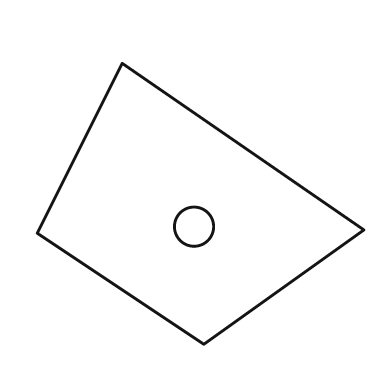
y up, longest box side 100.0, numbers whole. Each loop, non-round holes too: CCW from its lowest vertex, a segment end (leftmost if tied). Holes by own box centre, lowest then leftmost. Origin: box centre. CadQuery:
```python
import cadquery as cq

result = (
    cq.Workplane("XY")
    .moveTo(1.0, -43.0)
    .lineTo(50.0, -8.0)
    .lineTo(-24.0, 43.0)
    .lineTo(-50.0, -9.0)
    .close()
    .moveTo(-2.0, -7.0)
    .circle(6.0)
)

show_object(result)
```